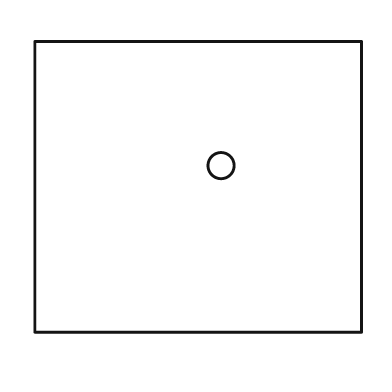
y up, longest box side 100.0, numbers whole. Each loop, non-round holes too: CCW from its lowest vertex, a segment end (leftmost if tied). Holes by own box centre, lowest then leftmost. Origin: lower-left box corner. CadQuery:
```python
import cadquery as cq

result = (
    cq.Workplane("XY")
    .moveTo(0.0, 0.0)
    .lineTo(100.0, 0.0)
    .lineTo(100.0, 89.0)
    .lineTo(0.0, 89.0)
    .close()
    .moveTo(57.0, 51.0)
    .circle(4.0)
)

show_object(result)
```